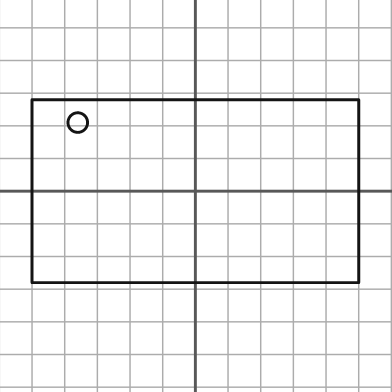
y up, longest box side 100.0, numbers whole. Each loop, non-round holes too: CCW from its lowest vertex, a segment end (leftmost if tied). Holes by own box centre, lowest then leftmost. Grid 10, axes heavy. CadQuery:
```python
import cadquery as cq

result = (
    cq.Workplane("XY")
    .moveTo(-50.0, -28.0)
    .lineTo(50.0, -28.0)
    .lineTo(50.0, 28.0)
    .lineTo(-50.0, 28.0)
    .close()
    .moveTo(-36.0, 21.0)
    .circle(3.0)
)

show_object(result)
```